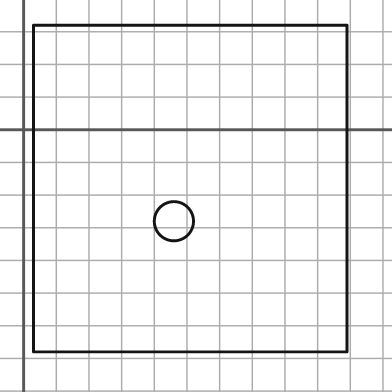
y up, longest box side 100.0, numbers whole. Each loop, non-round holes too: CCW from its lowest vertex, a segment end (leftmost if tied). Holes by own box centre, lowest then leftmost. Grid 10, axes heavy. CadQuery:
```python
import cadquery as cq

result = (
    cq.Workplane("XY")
    .moveTo(3.0, -68.0)
    .lineTo(99.0, -68.0)
    .lineTo(99.0, 32.0)
    .lineTo(3.0, 32.0)
    .close()
    .moveTo(46.0, -28.0)
    .circle(6.0)
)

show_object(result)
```